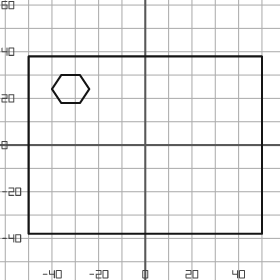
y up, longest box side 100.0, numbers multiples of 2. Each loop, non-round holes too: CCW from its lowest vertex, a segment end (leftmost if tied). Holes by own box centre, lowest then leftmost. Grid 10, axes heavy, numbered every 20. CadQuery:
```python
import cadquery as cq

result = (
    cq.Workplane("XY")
    .moveTo(-50.0, -38.0)
    .lineTo(50.0, -38.0)
    .lineTo(50.0, 38.0)
    .lineTo(-50.0, 38.0)
    .close()
    .moveTo(-36.0, 18.0)
    .lineTo(-28.0, 18.0)
    .lineTo(-24.0, 24.0)
    .lineTo(-28.0, 30.0)
    .lineTo(-36.0, 30.0)
    .lineTo(-40.0, 24.0)
    .close()
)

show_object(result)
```